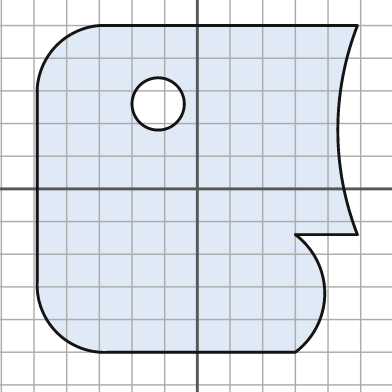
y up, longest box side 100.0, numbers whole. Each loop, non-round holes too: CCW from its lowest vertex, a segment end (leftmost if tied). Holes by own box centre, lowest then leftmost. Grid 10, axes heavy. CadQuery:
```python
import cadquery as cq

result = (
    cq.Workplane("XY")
    .moveTo(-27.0, -50.0)
    .lineTo(30.0, -50.0)
    .threePointArc((39.0, -32.0), (30.0, -14.0))
    .lineTo(49.0, -14.0)
    .threePointArc((43.0, 18.0), (49.0, 50.0))
    .lineTo(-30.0, 50.0)
    .threePointArc((-43.0, 44.0), (-49.0, 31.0))
    .lineTo(-49.0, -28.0)
    .threePointArc((-43.0, -44.0), (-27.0, -50.0))
    .close()
    .moveTo(-12.0, 26.0)
    .circle(8.0)
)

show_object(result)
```